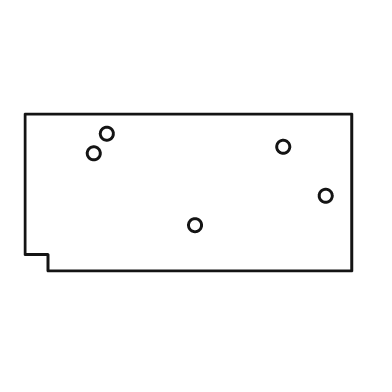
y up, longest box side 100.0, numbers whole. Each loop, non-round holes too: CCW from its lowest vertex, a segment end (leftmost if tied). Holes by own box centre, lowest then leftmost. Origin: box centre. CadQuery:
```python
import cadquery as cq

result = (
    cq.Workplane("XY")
    .moveTo(-43.0, -24.0)
    .lineTo(50.0, -24.0)
    .lineTo(50.0, 24.0)
    .lineTo(-50.0, 24.0)
    .lineTo(-50.0, -19.0)
    .lineTo(-43.0, -19.0)
    .close()
    .moveTo(2.0, -10.0)
    .circle(2.0)
    .moveTo(42.0, -1.0)
    .circle(2.0)
    .moveTo(-29.0, 12.0)
    .circle(2.0)
    .moveTo(29.0, 14.0)
    .circle(2.0)
    .moveTo(-25.0, 18.0)
    .circle(2.0)
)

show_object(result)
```